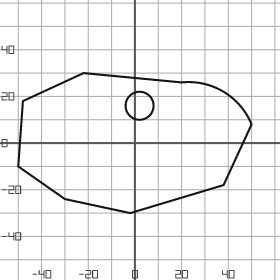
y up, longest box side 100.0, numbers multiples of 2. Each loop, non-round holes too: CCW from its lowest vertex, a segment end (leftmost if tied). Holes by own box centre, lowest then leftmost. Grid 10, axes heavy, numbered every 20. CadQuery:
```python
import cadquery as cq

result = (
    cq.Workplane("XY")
    .moveTo(-2.0, -30.0)
    .lineTo(38.0, -18.0)
    .lineTo(50.0, 8.0)
    .threePointArc((38.0, 22.0), (20.0, 26.0))
    .lineTo(-22.0, 30.0)
    .lineTo(-48.0, 18.0)
    .lineTo(-50.0, -10.0)
    .lineTo(-30.0, -24.0)
    .close()
    .moveTo(2.0, 16.0)
    .circle(6.0)
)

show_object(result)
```